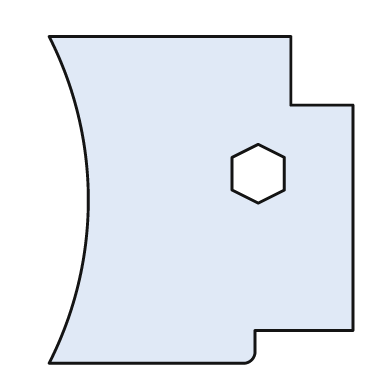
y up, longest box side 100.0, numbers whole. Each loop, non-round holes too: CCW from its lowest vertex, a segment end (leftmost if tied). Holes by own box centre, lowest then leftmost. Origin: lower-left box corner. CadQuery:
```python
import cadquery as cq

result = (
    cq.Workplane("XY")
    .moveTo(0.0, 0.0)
    .lineTo(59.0, 0.0)
    .threePointArc((62.0, 1.0), (63.0, 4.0))
    .lineTo(63.0, 10.0)
    .lineTo(93.0, 10.0)
    .lineTo(93.0, 79.0)
    .lineTo(74.0, 79.0)
    .lineTo(74.0, 100.0)
    .lineTo(0.0, 100.0)
    .threePointArc((12.0, 50.0), (0.0, 0.0))
    .close()
    .moveTo(64.0, 49.0)
    .lineTo(72.0, 53.0)
    .lineTo(72.0, 63.0)
    .lineTo(64.0, 67.0)
    .lineTo(56.0, 63.0)
    .lineTo(56.0, 53.0)
    .close()
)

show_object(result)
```